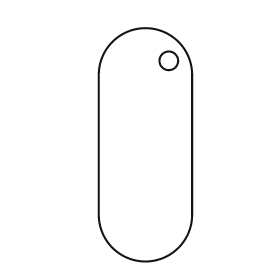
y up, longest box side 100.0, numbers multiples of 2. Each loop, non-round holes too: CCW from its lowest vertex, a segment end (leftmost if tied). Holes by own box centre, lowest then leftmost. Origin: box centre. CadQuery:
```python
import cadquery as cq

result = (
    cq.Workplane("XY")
    .moveTo(-20.0, -30.0)
    .threePointArc((0.0, -50.0), (20.0, -30.0))
    .lineTo(20.0, 30.0)
    .threePointArc((0.0, 50.0), (-20.0, 30.0))
    .close()
    .moveTo(10.0, 36.0)
    .circle(4.0)
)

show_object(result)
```